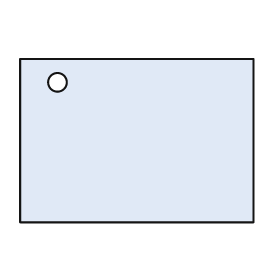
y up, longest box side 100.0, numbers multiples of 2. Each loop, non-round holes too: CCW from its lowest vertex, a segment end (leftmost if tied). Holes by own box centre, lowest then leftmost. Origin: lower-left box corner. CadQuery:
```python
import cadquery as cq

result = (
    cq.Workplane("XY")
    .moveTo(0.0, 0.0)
    .lineTo(100.0, 0.0)
    .lineTo(100.0, 70.0)
    .lineTo(0.0, 70.0)
    .close()
    .moveTo(16.0, 60.0)
    .circle(4.0)
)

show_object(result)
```